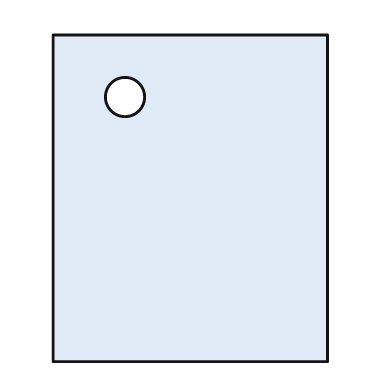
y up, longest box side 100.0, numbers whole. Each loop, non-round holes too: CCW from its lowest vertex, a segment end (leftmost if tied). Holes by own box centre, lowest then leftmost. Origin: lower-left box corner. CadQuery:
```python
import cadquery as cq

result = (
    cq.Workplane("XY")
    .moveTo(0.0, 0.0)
    .lineTo(84.0, 0.0)
    .lineTo(84.0, 100.0)
    .lineTo(0.0, 100.0)
    .close()
    .moveTo(22.0, 81.0)
    .circle(6.0)
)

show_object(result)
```